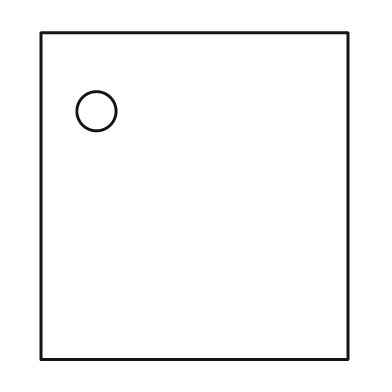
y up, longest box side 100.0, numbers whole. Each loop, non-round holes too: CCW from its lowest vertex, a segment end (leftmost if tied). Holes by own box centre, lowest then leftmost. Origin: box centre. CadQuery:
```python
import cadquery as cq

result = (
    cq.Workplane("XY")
    .moveTo(-47.0, -50.0)
    .lineTo(47.0, -50.0)
    .lineTo(47.0, 50.0)
    .lineTo(-47.0, 50.0)
    .close()
    .moveTo(-30.0, 26.0)
    .circle(6.0)
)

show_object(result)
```